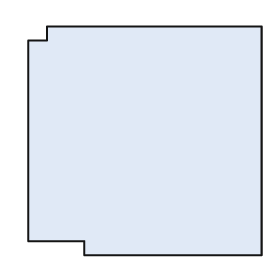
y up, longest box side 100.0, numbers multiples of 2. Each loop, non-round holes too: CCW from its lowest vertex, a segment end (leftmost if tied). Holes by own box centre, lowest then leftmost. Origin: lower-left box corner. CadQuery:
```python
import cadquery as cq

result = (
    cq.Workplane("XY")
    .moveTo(24.0, 0.0)
    .lineTo(100.0, 0.0)
    .lineTo(100.0, 98.0)
    .lineTo(8.0, 98.0)
    .lineTo(8.0, 92.0)
    .lineTo(0.0, 92.0)
    .lineTo(0.0, 6.0)
    .lineTo(24.0, 6.0)
    .close()
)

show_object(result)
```